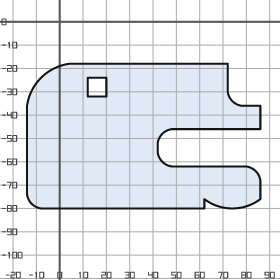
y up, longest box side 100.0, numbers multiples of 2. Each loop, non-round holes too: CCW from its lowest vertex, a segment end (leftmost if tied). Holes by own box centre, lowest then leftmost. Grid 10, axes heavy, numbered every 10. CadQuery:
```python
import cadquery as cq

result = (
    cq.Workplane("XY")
    .moveTo(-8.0, -80.0)
    .lineTo(62.0, -80.0)
    .lineTo(62.0, -76.0)
    .threePointArc((74.0, -80.0), (86.0, -76.0))
    .lineTo(86.0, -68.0)
    .threePointArc((84.0, -64.0), (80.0, -62.0))
    .lineTo(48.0, -62.0)
    .threePointArc((44.0, -60.0), (42.0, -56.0))
    .lineTo(42.0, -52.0)
    .threePointArc((44.0, -48.0), (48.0, -46.0))
    .lineTo(86.0, -46.0)
    .lineTo(86.0, -36.0)
    .lineTo(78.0, -36.0)
    .threePointArc((74.0, -34.0), (72.0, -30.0))
    .lineTo(72.0, -18.0)
    .lineTo(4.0, -18.0)
    .threePointArc((-8.0, -24.0), (-14.0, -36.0))
    .lineTo(-14.0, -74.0)
    .threePointArc((-12.0, -78.0), (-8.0, -80.0))
    .close()
    .moveTo(12.0, -32.0)
    .lineTo(20.0, -32.0)
    .lineTo(20.0, -24.0)
    .lineTo(12.0, -24.0)
    .close()
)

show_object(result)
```